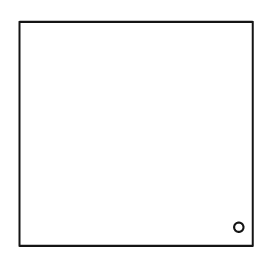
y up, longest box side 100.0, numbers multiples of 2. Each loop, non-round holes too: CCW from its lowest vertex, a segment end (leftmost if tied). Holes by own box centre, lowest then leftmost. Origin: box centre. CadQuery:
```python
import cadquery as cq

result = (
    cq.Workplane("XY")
    .moveTo(-50.0, -48.0)
    .lineTo(50.0, -48.0)
    .lineTo(50.0, 48.0)
    .lineTo(-50.0, 48.0)
    .close()
    .moveTo(44.0, -40.0)
    .circle(2.0)
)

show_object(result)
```